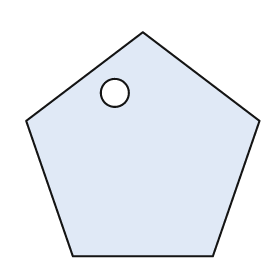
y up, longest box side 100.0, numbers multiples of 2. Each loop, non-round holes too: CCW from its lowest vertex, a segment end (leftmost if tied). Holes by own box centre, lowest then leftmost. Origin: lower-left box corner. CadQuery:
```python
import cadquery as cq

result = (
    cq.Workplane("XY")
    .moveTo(20.0, 0.0)
    .lineTo(80.0, 0.0)
    .lineTo(100.0, 58.0)
    .lineTo(50.0, 96.0)
    .lineTo(0.0, 58.0)
    .close()
    .moveTo(38.0, 70.0)
    .circle(6.0)
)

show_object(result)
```